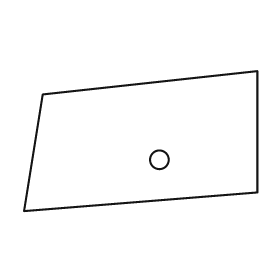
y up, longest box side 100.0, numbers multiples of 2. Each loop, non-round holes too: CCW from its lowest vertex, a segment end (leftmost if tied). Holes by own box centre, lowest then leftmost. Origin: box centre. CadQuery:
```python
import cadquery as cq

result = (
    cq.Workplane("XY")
    .moveTo(-50.0, -30.0)
    .lineTo(50.0, -22.0)
    .lineTo(50.0, 30.0)
    .lineTo(-42.0, 20.0)
    .close()
    .moveTo(8.0, -8.0)
    .circle(4.0)
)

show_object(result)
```